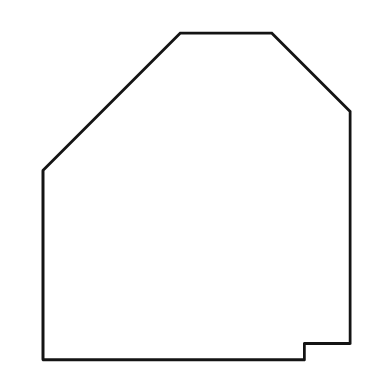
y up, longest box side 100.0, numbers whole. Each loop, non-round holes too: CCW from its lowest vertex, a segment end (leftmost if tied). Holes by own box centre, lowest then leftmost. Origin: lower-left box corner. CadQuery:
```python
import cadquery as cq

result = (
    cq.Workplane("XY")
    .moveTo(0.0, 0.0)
    .lineTo(80.0, 0.0)
    .lineTo(80.0, 5.0)
    .lineTo(94.0, 5.0)
    .lineTo(94.0, 76.0)
    .lineTo(70.0, 100.0)
    .lineTo(42.0, 100.0)
    .lineTo(0.0, 58.0)
    .close()
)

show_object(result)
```